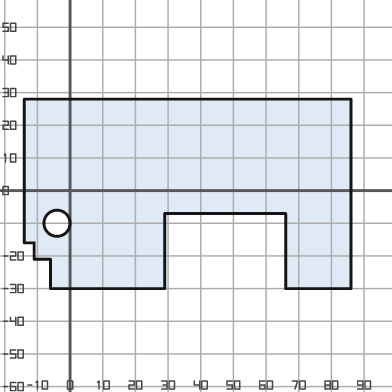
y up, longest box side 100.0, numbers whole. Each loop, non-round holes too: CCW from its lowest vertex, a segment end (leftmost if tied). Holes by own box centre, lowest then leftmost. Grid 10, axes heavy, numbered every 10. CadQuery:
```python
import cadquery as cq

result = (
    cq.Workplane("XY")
    .moveTo(-6.0, -30.0)
    .lineTo(29.0, -30.0)
    .lineTo(29.0, -7.0)
    .lineTo(66.0, -7.0)
    .lineTo(66.0, -30.0)
    .lineTo(86.0, -30.0)
    .lineTo(86.0, 28.0)
    .lineTo(-14.0, 28.0)
    .lineTo(-14.0, -16.0)
    .lineTo(-11.0, -16.0)
    .lineTo(-11.0, -21.0)
    .lineTo(-6.0, -21.0)
    .close()
    .moveTo(-4.0, -10.0)
    .circle(4.0)
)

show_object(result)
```